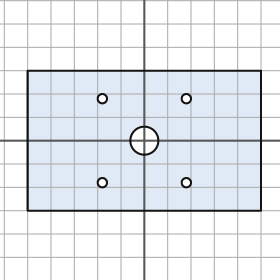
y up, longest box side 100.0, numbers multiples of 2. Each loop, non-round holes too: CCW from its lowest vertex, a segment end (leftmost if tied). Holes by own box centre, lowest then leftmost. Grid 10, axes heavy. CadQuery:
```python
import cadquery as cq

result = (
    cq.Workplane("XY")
    .moveTo(-50.0, -30.0)
    .lineTo(50.0, -30.0)
    .lineTo(50.0, 30.0)
    .lineTo(-50.0, 30.0)
    .close()
    .moveTo(-18.0, -18.0)
    .circle(2.0)
    .moveTo(18.0, -18.0)
    .circle(2.0)
    .moveTo(0.0, 0.0)
    .circle(6.0)
    .moveTo(-18.0, 18.0)
    .circle(2.0)
    .moveTo(18.0, 18.0)
    .circle(2.0)
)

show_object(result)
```